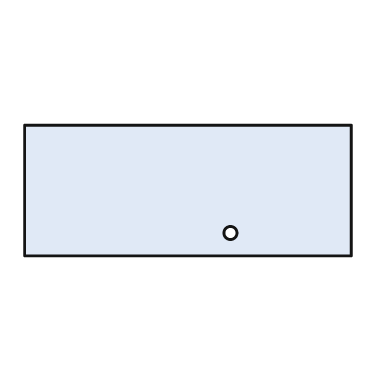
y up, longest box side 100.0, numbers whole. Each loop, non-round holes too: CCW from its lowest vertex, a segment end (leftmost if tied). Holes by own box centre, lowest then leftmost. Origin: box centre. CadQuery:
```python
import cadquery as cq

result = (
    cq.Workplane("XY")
    .moveTo(-50.0, -20.0)
    .lineTo(50.0, -20.0)
    .lineTo(50.0, 20.0)
    .lineTo(-50.0, 20.0)
    .close()
    .moveTo(13.0, -13.0)
    .circle(2.0)
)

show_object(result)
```